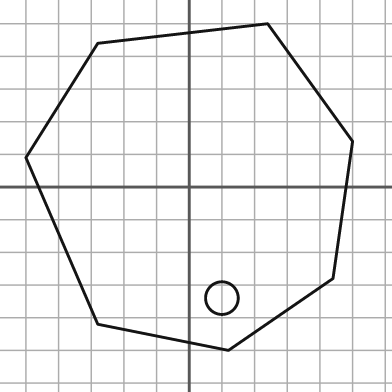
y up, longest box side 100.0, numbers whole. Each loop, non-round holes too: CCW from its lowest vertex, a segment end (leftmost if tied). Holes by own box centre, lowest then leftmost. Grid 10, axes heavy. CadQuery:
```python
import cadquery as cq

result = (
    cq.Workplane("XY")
    .moveTo(12.0, -50.0)
    .lineTo(44.0, -28.0)
    .lineTo(50.0, 14.0)
    .lineTo(24.0, 50.0)
    .lineTo(-28.0, 44.0)
    .lineTo(-50.0, 9.0)
    .lineTo(-28.0, -42.0)
    .close()
    .moveTo(10.0, -34.0)
    .circle(5.0)
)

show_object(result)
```